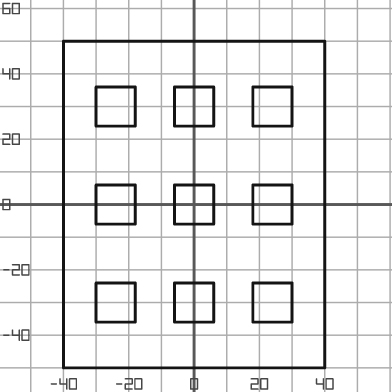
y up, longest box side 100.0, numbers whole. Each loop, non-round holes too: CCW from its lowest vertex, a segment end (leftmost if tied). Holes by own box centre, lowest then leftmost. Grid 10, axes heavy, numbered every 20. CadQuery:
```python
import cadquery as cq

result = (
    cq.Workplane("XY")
    .moveTo(-40.0, -50.0)
    .lineTo(40.0, -50.0)
    .lineTo(40.0, 50.0)
    .lineTo(-40.0, 50.0)
    .close()
    .moveTo(-30.0, -36.0)
    .lineTo(-18.0, -36.0)
    .lineTo(-18.0, -24.0)
    .lineTo(-30.0, -24.0)
    .close()
    .moveTo(-6.0, -36.0)
    .lineTo(6.0, -36.0)
    .lineTo(6.0, -24.0)
    .lineTo(-6.0, -24.0)
    .close()
    .moveTo(18.0, -36.0)
    .lineTo(30.0, -36.0)
    .lineTo(30.0, -24.0)
    .lineTo(18.0, -24.0)
    .close()
    .moveTo(-30.0, -6.0)
    .lineTo(-18.0, -6.0)
    .lineTo(-18.0, 6.0)
    .lineTo(-30.0, 6.0)
    .close()
    .moveTo(-6.0, -6.0)
    .lineTo(6.0, -6.0)
    .lineTo(6.0, 6.0)
    .lineTo(-6.0, 6.0)
    .close()
    .moveTo(18.0, -6.0)
    .lineTo(30.0, -6.0)
    .lineTo(30.0, 6.0)
    .lineTo(18.0, 6.0)
    .close()
    .moveTo(-30.0, 24.0)
    .lineTo(-18.0, 24.0)
    .lineTo(-18.0, 36.0)
    .lineTo(-30.0, 36.0)
    .close()
    .moveTo(-6.0, 24.0)
    .lineTo(6.0, 24.0)
    .lineTo(6.0, 36.0)
    .lineTo(-6.0, 36.0)
    .close()
    .moveTo(18.0, 24.0)
    .lineTo(30.0, 24.0)
    .lineTo(30.0, 36.0)
    .lineTo(18.0, 36.0)
    .close()
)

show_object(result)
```